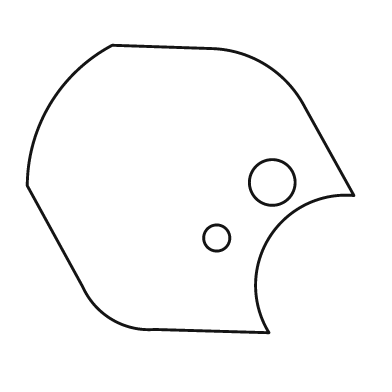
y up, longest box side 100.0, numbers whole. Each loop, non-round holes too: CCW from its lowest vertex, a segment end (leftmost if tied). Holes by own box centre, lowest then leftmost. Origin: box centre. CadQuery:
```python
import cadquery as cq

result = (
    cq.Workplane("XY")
    .moveTo(24.0, -44.0)
    .threePointArc((24.0, -15.0), (50.0, -2.0))
    .lineTo(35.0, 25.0)
    .threePointArc((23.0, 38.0), (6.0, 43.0))
    .lineTo(-24.0, 44.0)
    .threePointArc((-43.0, 26.0), (-50.0, 1.0))
    .lineTo(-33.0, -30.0)
    .threePointArc((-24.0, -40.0), (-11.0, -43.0))
    .close()
    .moveTo(8.0, -15.0)
    .circle(4.0)
    .moveTo(25.0, 2.0)
    .circle(7.0)
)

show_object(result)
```